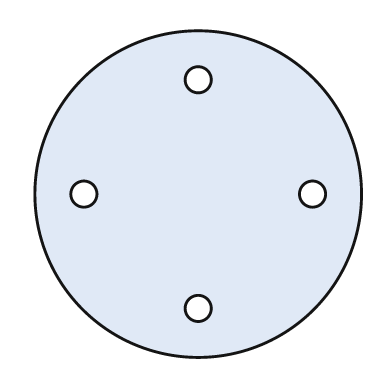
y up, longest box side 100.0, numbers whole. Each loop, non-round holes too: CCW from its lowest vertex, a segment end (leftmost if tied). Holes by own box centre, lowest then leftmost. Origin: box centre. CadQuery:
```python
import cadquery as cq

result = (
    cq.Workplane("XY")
    .moveTo(0.0, 0.0)
    .circle(50.0)
    .moveTo(0.0, -35.0)
    .circle(4.0)
    .moveTo(-35.0, 0.0)
    .circle(4.0)
    .moveTo(35.0, 0.0)
    .circle(4.0)
    .moveTo(0.0, 35.0)
    .circle(4.0)
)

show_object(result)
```